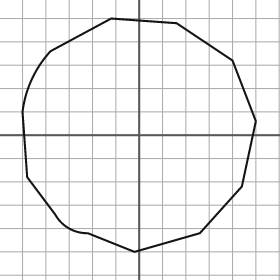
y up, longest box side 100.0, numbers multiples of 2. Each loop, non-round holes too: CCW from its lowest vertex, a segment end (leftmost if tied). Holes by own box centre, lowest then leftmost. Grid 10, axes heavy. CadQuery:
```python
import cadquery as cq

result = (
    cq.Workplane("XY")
    .moveTo(-2.0, -50.0)
    .lineTo(26.0, -42.0)
    .lineTo(44.0, -22.0)
    .lineTo(50.0, 6.0)
    .lineTo(40.0, 32.0)
    .lineTo(16.0, 48.0)
    .lineTo(-12.0, 50.0)
    .lineTo(-38.0, 36.0)
    .threePointArc((-46.0, 24.0), (-50.0, 10.0))
    .lineTo(-48.0, -18.0)
    .lineTo(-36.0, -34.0)
    .threePointArc((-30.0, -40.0), (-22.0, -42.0))
    .close()
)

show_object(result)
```